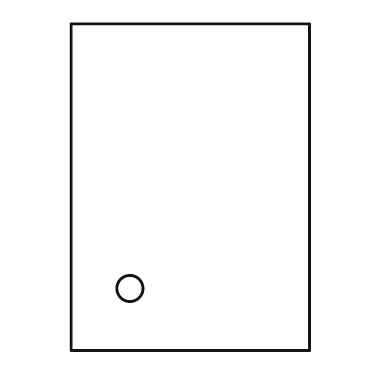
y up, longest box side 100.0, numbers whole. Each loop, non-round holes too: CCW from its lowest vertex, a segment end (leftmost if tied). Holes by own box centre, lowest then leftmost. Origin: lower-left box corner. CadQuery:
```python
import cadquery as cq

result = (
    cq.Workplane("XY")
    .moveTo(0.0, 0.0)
    .lineTo(73.0, 0.0)
    .lineTo(73.0, 100.0)
    .lineTo(0.0, 100.0)
    .close()
    .moveTo(18.0, 19.0)
    .circle(4.0)
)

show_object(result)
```